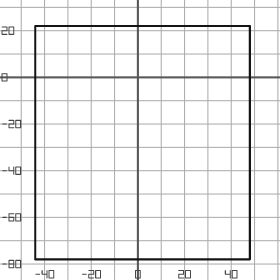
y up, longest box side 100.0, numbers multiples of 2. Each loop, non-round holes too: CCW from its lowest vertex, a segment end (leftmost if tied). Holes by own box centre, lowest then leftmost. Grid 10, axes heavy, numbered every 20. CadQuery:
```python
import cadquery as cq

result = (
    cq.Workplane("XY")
    .moveTo(-44.0, -78.0)
    .lineTo(48.0, -78.0)
    .lineTo(48.0, 22.0)
    .lineTo(-44.0, 22.0)
    .close()
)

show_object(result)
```